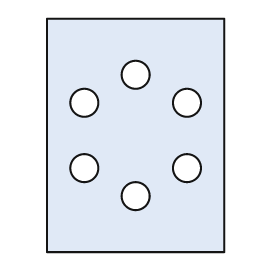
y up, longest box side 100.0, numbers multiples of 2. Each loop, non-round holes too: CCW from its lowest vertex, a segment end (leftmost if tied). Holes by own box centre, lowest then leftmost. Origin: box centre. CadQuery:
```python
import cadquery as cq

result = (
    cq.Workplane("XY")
    .moveTo(-38.0, -50.0)
    .lineTo(38.0, -50.0)
    .lineTo(38.0, 50.0)
    .lineTo(-38.0, 50.0)
    .close()
    .moveTo(0.0, -26.0)
    .circle(6.0)
    .moveTo(-22.0, -14.0)
    .circle(6.0)
    .moveTo(22.0, -14.0)
    .circle(6.0)
    .moveTo(-22.0, 14.0)
    .circle(6.0)
    .moveTo(22.0, 14.0)
    .circle(6.0)
    .moveTo(0.0, 26.0)
    .circle(6.0)
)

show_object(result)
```